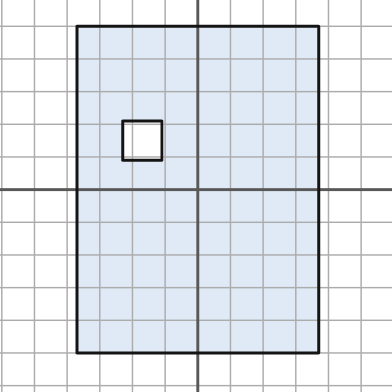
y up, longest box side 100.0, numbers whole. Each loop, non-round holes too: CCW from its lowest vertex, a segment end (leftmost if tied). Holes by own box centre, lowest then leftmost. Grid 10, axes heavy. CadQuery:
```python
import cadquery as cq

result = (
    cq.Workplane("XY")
    .moveTo(-37.0, -50.0)
    .lineTo(37.0, -50.0)
    .lineTo(37.0, 50.0)
    .lineTo(-37.0, 50.0)
    .close()
    .moveTo(-23.0, 9.0)
    .lineTo(-11.0, 9.0)
    .lineTo(-11.0, 21.0)
    .lineTo(-23.0, 21.0)
    .close()
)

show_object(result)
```